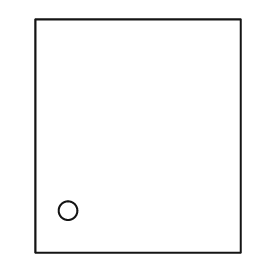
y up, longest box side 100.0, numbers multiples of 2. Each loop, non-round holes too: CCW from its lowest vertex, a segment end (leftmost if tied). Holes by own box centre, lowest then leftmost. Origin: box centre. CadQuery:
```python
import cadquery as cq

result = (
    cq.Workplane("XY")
    .moveTo(-44.0, -50.0)
    .lineTo(44.0, -50.0)
    .lineTo(44.0, 50.0)
    .lineTo(-44.0, 50.0)
    .close()
    .moveTo(-30.0, -32.0)
    .circle(4.0)
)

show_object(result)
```